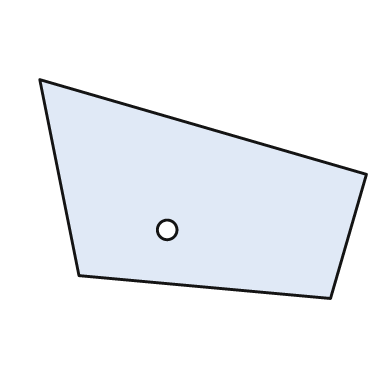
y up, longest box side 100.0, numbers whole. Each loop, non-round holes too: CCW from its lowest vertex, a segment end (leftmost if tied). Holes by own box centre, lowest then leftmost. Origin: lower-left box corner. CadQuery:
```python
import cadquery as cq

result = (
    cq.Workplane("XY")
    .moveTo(89.0, 0.0)
    .lineTo(100.0, 38.0)
    .lineTo(0.0, 67.0)
    .lineTo(12.0, 7.0)
    .close()
    .moveTo(39.0, 21.0)
    .circle(3.0)
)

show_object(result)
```